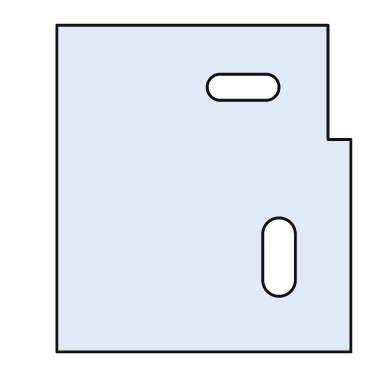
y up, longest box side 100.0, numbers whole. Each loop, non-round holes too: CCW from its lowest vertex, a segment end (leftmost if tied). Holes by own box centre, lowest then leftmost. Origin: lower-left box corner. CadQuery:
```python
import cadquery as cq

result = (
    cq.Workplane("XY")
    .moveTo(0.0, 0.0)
    .lineTo(90.0, 0.0)
    .lineTo(90.0, 65.0)
    .lineTo(83.0, 65.0)
    .lineTo(83.0, 100.0)
    .lineTo(0.0, 100.0)
    .close()
    .moveTo(63.0, 22.0)
    .threePointArc((68.0, 17.0), (73.0, 22.0))
    .lineTo(73.0, 36.0)
    .threePointArc((68.0, 41.0), (63.0, 36.0))
    .close()
    .moveTo(50.0, 77.0)
    .lineTo(64.0, 77.0)
    .threePointArc((68.0, 81.0), (64.0, 85.0))
    .lineTo(50.0, 85.0)
    .threePointArc((46.0, 81.0), (50.0, 77.0))
    .close()
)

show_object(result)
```